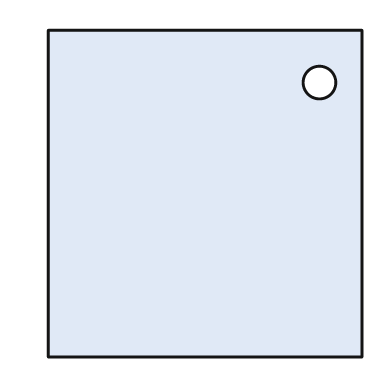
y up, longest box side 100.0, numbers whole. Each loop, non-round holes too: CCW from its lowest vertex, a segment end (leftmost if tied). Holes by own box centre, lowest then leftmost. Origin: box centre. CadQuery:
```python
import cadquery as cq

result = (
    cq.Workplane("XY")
    .moveTo(-48.0, -50.0)
    .lineTo(48.0, -50.0)
    .lineTo(48.0, 50.0)
    .lineTo(-48.0, 50.0)
    .close()
    .moveTo(35.0, 34.0)
    .circle(5.0)
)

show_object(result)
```